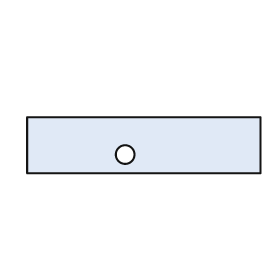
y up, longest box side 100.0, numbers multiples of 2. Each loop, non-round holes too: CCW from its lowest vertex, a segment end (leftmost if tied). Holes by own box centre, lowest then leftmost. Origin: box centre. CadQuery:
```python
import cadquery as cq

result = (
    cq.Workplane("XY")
    .moveTo(-50.0, -12.0)
    .lineTo(50.0, -12.0)
    .lineTo(50.0, 12.0)
    .lineTo(-50.0, 12.0)
    .close()
    .moveTo(-8.0, -4.0)
    .circle(4.0)
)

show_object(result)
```